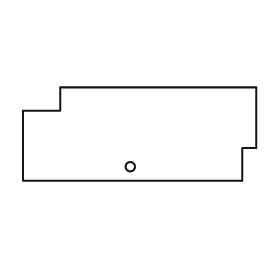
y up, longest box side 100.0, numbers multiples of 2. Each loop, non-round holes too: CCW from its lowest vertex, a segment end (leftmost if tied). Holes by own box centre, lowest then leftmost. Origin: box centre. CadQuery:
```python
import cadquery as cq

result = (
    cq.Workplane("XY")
    .moveTo(-50.0, -20.0)
    .lineTo(44.0, -20.0)
    .lineTo(44.0, -6.0)
    .lineTo(50.0, -6.0)
    .lineTo(50.0, 20.0)
    .lineTo(-34.0, 20.0)
    .lineTo(-34.0, 10.0)
    .lineTo(-50.0, 10.0)
    .close()
    .moveTo(-4.0, -14.0)
    .circle(2.0)
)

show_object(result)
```